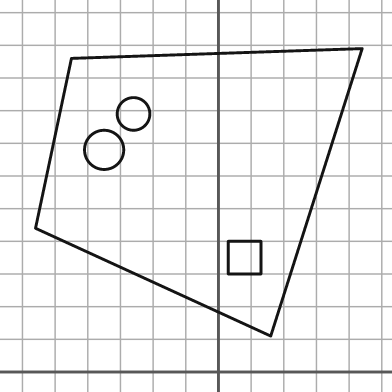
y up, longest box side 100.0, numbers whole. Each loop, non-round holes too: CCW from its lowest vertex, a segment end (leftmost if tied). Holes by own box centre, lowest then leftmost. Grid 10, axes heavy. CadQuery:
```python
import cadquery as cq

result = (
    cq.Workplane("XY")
    .moveTo(16.0, 11.0)
    .lineTo(44.0, 99.0)
    .lineTo(-45.0, 96.0)
    .lineTo(-56.0, 44.0)
    .close()
    .moveTo(3.0, 30.0)
    .lineTo(13.0, 30.0)
    .lineTo(13.0, 40.0)
    .lineTo(3.0, 40.0)
    .close()
    .moveTo(-35.0, 68.0)
    .circle(6.0)
    .moveTo(-26.0, 79.0)
    .circle(5.0)
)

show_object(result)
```